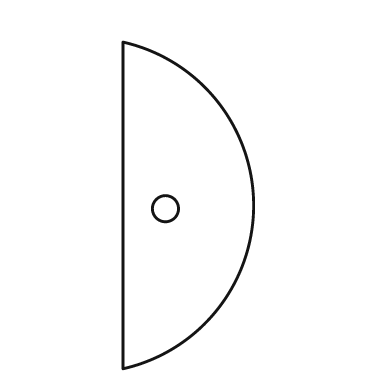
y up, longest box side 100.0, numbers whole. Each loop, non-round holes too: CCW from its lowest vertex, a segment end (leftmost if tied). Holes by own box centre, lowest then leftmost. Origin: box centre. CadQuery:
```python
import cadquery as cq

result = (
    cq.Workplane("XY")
    .moveTo(-20.0, -50.0)
    .threePointArc((20.0, 0.0), (-20.0, 50.0))
    .close()
    .moveTo(-7.0, -1.0)
    .circle(4.0)
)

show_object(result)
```